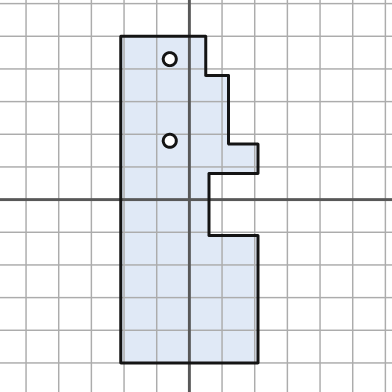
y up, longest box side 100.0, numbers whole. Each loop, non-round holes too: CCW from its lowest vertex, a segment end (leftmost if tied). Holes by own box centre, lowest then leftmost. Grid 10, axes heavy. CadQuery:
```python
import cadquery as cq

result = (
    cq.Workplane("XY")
    .moveTo(-21.0, -50.0)
    .lineTo(21.0, -50.0)
    .lineTo(21.0, -11.0)
    .lineTo(6.0, -11.0)
    .lineTo(6.0, 8.0)
    .lineTo(21.0, 8.0)
    .lineTo(21.0, 17.0)
    .lineTo(12.0, 17.0)
    .lineTo(12.0, 38.0)
    .lineTo(5.0, 38.0)
    .lineTo(5.0, 50.0)
    .lineTo(-21.0, 50.0)
    .close()
    .moveTo(-6.0, 18.0)
    .circle(2.0)
    .moveTo(-6.0, 43.0)
    .circle(2.0)
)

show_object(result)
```